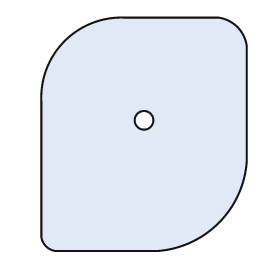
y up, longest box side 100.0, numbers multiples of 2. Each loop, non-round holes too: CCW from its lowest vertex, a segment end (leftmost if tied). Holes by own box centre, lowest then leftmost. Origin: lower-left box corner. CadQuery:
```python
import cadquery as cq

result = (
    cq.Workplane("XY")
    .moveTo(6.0, 0.0)
    .lineTo(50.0, 0.0)
    .threePointArc((76.0, 12.0), (88.0, 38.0))
    .lineTo(88.0, 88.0)
    .threePointArc((84.0, 96.0), (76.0, 100.0))
    .lineTo(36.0, 100.0)
    .threePointArc((10.0, 90.0), (0.0, 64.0))
    .lineTo(0.0, 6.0)
    .threePointArc((2.0, 2.0), (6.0, 0.0))
    .close()
    .moveTo(44.0, 56.0)
    .circle(4.0)
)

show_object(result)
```